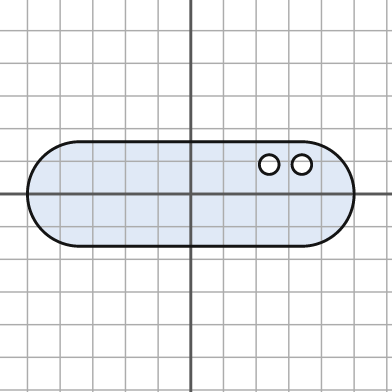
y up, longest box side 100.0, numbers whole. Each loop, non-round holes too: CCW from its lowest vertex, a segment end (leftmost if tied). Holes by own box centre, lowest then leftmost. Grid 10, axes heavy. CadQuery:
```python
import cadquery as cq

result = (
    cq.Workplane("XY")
    .moveTo(-34.0, -16.0)
    .lineTo(34.0, -16.0)
    .threePointArc((50.0, 0.0), (34.0, 16.0))
    .lineTo(-34.0, 16.0)
    .threePointArc((-50.0, 0.0), (-34.0, -16.0))
    .close()
    .moveTo(24.0, 9.0)
    .circle(3.0)
    .moveTo(34.0, 9.0)
    .circle(3.0)
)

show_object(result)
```